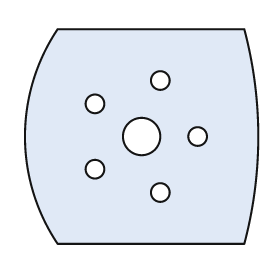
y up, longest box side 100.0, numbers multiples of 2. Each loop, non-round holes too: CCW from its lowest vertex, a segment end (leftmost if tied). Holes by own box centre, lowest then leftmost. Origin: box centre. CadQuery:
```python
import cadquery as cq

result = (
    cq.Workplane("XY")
    .moveTo(-36.0, -46.0)
    .lineTo(44.0, -46.0)
    .threePointArc((50.0, 0.0), (44.0, 46.0))
    .lineTo(-36.0, 46.0)
    .threePointArc((-50.0, 0.0), (-36.0, -46.0))
    .close()
    .moveTo(8.0, -24.0)
    .circle(4.0)
    .moveTo(-20.0, -14.0)
    .circle(4.0)
    .moveTo(0.0, 0.0)
    .circle(8.0)
    .moveTo(24.0, 0.0)
    .circle(4.0)
    .moveTo(-20.0, 14.0)
    .circle(4.0)
    .moveTo(8.0, 24.0)
    .circle(4.0)
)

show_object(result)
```